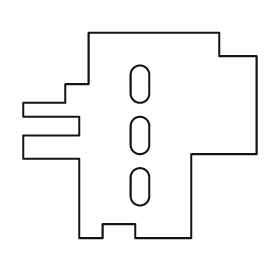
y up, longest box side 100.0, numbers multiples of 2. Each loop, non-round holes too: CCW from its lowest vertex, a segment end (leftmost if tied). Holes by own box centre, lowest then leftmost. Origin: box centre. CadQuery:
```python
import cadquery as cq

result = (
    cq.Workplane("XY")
    .moveTo(-26.0, -44.0)
    .lineTo(-16.0, -44.0)
    .lineTo(-16.0, -38.0)
    .lineTo(-2.0, -38.0)
    .lineTo(-2.0, -44.0)
    .lineTo(22.0, -44.0)
    .lineTo(22.0, -8.0)
    .lineTo(50.0, -8.0)
    .lineTo(50.0, 34.0)
    .lineTo(34.0, 34.0)
    .lineTo(34.0, 44.0)
    .lineTo(-22.0, 44.0)
    .lineTo(-22.0, 22.0)
    .lineTo(-32.0, 22.0)
    .lineTo(-32.0, 14.0)
    .lineTo(-50.0, 14.0)
    .lineTo(-50.0, 8.0)
    .lineTo(-26.0, 8.0)
    .lineTo(-26.0, 0.0)
    .lineTo(-50.0, 0.0)
    .lineTo(-50.0, -10.0)
    .lineTo(-26.0, -10.0)
    .close()
    .moveTo(-4.0, -26.0)
    .threePointArc((0.0, -30.0), (4.0, -26.0))
    .lineTo(4.0, -18.0)
    .threePointArc((0.0, -14.0), (-4.0, -18.0))
    .close()
    .moveTo(-4.0, -4.0)
    .threePointArc((0.0, -8.0), (4.0, -4.0))
    .lineTo(4.0, 4.0)
    .threePointArc((0.0, 8.0), (-4.0, 4.0))
    .close()
    .moveTo(-4.0, 18.0)
    .threePointArc((0.0, 14.0), (4.0, 18.0))
    .lineTo(4.0, 26.0)
    .threePointArc((0.0, 30.0), (-4.0, 26.0))
    .close()
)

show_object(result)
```